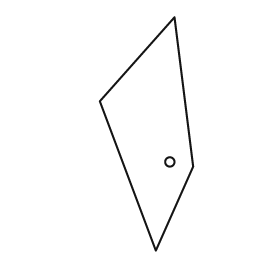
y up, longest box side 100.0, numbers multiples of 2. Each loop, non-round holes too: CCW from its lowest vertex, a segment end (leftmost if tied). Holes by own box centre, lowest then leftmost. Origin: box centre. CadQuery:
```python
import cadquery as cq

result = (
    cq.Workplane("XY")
    .moveTo(4.0, -50.0)
    .lineTo(20.0, -14.0)
    .lineTo(12.0, 50.0)
    .lineTo(-20.0, 14.0)
    .close()
    .moveTo(10.0, -12.0)
    .circle(2.0)
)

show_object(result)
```